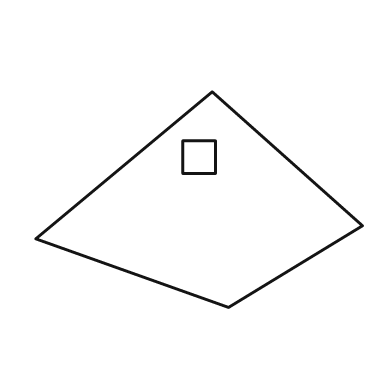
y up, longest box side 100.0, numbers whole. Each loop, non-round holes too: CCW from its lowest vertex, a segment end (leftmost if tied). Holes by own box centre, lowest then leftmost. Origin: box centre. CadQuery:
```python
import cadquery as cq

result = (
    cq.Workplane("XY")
    .moveTo(9.0, -33.0)
    .lineTo(50.0, -8.0)
    .lineTo(4.0, 33.0)
    .lineTo(-50.0, -12.0)
    .close()
    .moveTo(-5.0, 8.0)
    .lineTo(5.0, 8.0)
    .lineTo(5.0, 18.0)
    .lineTo(-5.0, 18.0)
    .close()
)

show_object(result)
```